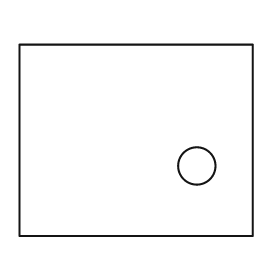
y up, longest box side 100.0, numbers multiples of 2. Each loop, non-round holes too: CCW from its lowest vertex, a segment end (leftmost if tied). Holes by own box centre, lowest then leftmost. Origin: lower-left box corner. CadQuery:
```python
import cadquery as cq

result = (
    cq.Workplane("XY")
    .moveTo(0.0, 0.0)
    .lineTo(100.0, 0.0)
    .lineTo(100.0, 82.0)
    .lineTo(0.0, 82.0)
    .close()
    .moveTo(76.0, 30.0)
    .circle(8.0)
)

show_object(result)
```